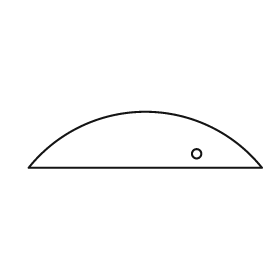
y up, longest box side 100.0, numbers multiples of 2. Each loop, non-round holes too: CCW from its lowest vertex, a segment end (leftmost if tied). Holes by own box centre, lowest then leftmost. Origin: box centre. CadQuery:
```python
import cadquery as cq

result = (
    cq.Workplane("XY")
    .moveTo(-50.0, -12.0)
    .lineTo(50.0, -12.0)
    .threePointArc((0.0, 12.0), (-50.0, -12.0))
    .close()
    .moveTo(22.0, -6.0)
    .circle(2.0)
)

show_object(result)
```